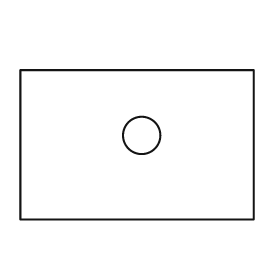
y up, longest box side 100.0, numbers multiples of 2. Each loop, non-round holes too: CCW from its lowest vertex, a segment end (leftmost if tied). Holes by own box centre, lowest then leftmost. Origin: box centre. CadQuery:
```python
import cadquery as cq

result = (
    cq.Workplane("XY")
    .moveTo(-50.0, -32.0)
    .lineTo(50.0, -32.0)
    .lineTo(50.0, 32.0)
    .lineTo(-50.0, 32.0)
    .close()
    .moveTo(2.0, 4.0)
    .circle(8.0)
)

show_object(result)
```